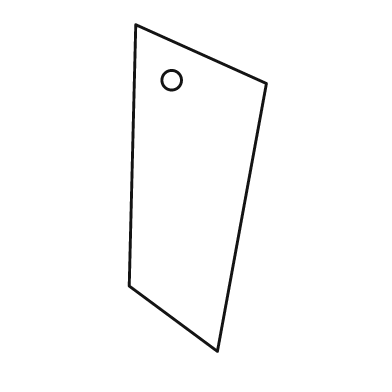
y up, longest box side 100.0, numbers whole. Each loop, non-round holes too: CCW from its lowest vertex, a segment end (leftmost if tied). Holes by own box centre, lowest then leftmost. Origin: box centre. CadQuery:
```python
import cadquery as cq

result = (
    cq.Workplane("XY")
    .moveTo(6.0, -50.0)
    .lineTo(21.0, 32.0)
    .lineTo(-19.0, 50.0)
    .lineTo(-21.0, -30.0)
    .close()
    .moveTo(-8.0, 33.0)
    .circle(3.0)
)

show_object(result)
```